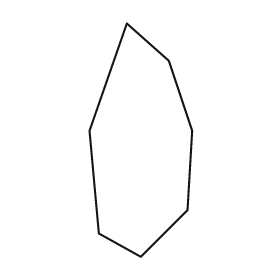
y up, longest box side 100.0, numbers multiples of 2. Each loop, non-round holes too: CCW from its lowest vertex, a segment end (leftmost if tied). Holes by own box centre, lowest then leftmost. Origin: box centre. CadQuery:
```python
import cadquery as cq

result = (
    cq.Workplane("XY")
    .moveTo(0.0, -50.0)
    .lineTo(20.0, -30.0)
    .lineTo(22.0, 4.0)
    .lineTo(12.0, 34.0)
    .lineTo(-6.0, 50.0)
    .lineTo(-22.0, 4.0)
    .lineTo(-18.0, -40.0)
    .close()
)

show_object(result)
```